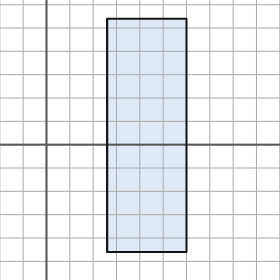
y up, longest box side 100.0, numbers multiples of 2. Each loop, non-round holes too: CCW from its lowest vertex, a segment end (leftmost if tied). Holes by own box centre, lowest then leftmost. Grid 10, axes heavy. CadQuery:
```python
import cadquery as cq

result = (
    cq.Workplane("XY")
    .moveTo(26.0, -46.0)
    .lineTo(60.0, -46.0)
    .lineTo(60.0, 54.0)
    .lineTo(26.0, 54.0)
    .close()
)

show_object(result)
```